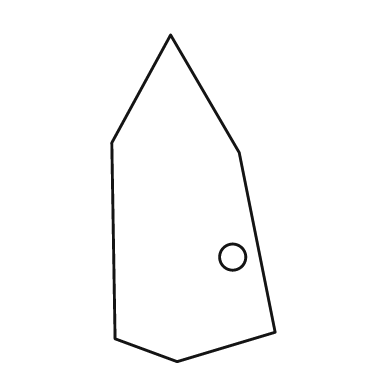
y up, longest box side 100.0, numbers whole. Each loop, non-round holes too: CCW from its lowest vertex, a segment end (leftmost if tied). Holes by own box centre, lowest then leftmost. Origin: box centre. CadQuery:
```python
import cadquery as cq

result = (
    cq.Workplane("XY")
    .moveTo(-5.0, -50.0)
    .lineTo(25.0, -41.0)
    .lineTo(14.0, 14.0)
    .lineTo(-7.0, 50.0)
    .lineTo(-25.0, 17.0)
    .lineTo(-24.0, -43.0)
    .close()
    .moveTo(12.0, -18.0)
    .circle(4.0)
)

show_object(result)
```